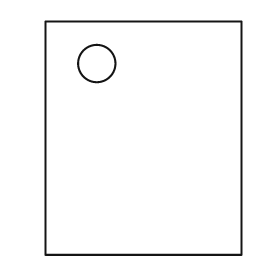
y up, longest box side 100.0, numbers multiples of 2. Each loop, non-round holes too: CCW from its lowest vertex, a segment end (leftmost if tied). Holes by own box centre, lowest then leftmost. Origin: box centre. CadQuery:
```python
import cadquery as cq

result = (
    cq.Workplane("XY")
    .moveTo(-42.0, -50.0)
    .lineTo(42.0, -50.0)
    .lineTo(42.0, 50.0)
    .lineTo(-42.0, 50.0)
    .close()
    .moveTo(-20.0, 32.0)
    .circle(8.0)
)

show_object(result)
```